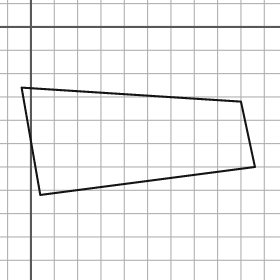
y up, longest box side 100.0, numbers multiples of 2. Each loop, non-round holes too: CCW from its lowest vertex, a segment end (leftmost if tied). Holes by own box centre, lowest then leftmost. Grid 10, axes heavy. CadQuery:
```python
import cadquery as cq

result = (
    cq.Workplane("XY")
    .moveTo(4.0, -72.0)
    .lineTo(96.0, -60.0)
    .lineTo(90.0, -32.0)
    .lineTo(-4.0, -26.0)
    .close()
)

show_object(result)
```